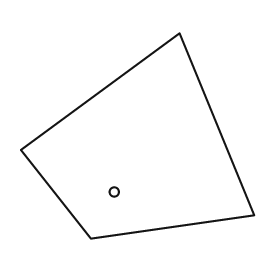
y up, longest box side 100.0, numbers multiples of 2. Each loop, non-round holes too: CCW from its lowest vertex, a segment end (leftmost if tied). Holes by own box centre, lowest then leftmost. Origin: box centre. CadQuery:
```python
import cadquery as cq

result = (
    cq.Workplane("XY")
    .moveTo(-20.0, -44.0)
    .lineTo(50.0, -34.0)
    .lineTo(18.0, 44.0)
    .lineTo(-50.0, -6.0)
    .close()
    .moveTo(-10.0, -24.0)
    .circle(2.0)
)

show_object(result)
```